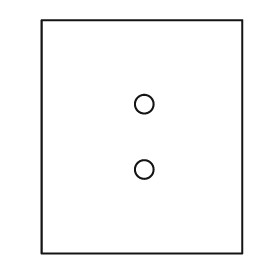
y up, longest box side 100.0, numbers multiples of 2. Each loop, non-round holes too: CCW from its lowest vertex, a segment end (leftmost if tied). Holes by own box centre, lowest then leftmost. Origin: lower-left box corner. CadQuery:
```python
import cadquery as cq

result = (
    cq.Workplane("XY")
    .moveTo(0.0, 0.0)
    .lineTo(86.0, 0.0)
    .lineTo(86.0, 100.0)
    .lineTo(0.0, 100.0)
    .close()
    .moveTo(44.0, 36.0)
    .circle(4.0)
    .moveTo(44.0, 64.0)
    .circle(4.0)
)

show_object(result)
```